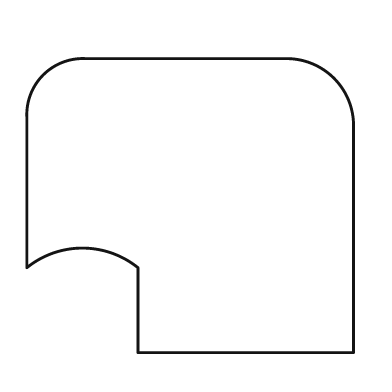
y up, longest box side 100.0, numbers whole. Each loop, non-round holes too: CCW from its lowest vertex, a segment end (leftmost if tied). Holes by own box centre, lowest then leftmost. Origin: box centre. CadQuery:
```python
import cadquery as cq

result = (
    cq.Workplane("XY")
    .moveTo(-16.0, -45.0)
    .lineTo(50.0, -45.0)
    .lineTo(50.0, 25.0)
    .threePointArc((44.0, 39.0), (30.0, 45.0))
    .lineTo(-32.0, 45.0)
    .threePointArc((-45.0, 40.0), (-50.0, 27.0))
    .lineTo(-50.0, -19.0)
    .threePointArc((-33.0, -13.0), (-16.0, -19.0))
    .close()
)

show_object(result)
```